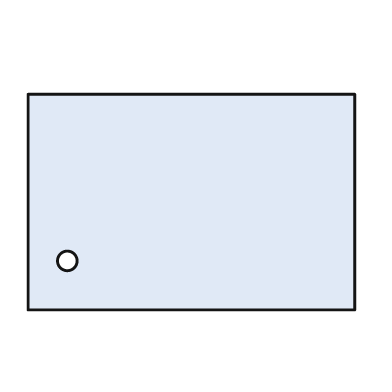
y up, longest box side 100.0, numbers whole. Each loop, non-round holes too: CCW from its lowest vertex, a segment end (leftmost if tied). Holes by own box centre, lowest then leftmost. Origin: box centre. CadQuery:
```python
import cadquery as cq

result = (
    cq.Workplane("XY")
    .moveTo(-50.0, -33.0)
    .lineTo(50.0, -33.0)
    .lineTo(50.0, 33.0)
    .lineTo(-50.0, 33.0)
    .close()
    .moveTo(-38.0, -18.0)
    .circle(3.0)
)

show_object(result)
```